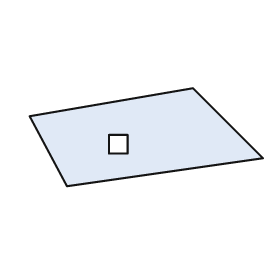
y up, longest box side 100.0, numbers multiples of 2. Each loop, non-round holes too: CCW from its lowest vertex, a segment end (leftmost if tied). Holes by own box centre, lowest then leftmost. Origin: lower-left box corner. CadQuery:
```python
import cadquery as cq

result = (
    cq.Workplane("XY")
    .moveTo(16.0, 0.0)
    .lineTo(100.0, 12.0)
    .lineTo(70.0, 42.0)
    .lineTo(0.0, 30.0)
    .close()
    .moveTo(34.0, 14.0)
    .lineTo(42.0, 14.0)
    .lineTo(42.0, 22.0)
    .lineTo(34.0, 22.0)
    .close()
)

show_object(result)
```